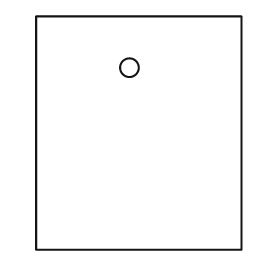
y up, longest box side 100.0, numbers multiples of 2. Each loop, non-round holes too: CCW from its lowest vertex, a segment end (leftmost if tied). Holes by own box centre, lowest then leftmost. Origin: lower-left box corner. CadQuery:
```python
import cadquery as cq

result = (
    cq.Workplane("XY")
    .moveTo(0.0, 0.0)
    .lineTo(88.0, 0.0)
    .lineTo(88.0, 100.0)
    .lineTo(0.0, 100.0)
    .close()
    .moveTo(40.0, 78.0)
    .circle(4.0)
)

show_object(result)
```